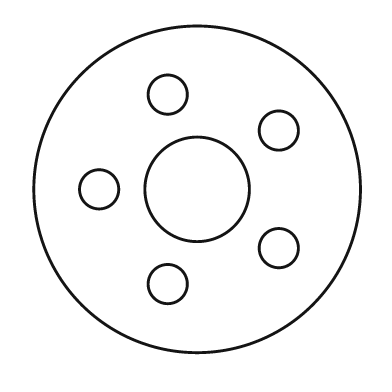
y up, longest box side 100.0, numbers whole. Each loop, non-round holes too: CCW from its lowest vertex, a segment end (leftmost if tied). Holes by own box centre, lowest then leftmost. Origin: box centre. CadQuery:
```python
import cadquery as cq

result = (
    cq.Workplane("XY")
    .moveTo(0.0, 0.0)
    .circle(50.0)
    .moveTo(-9.0, -29.0)
    .circle(6.0)
    .moveTo(25.0, -18.0)
    .circle(6.0)
    .moveTo(-30.0, 0.0)
    .circle(6.0)
    .moveTo(0.0, 0.0)
    .circle(16.0)
    .moveTo(25.0, 18.0)
    .circle(6.0)
    .moveTo(-9.0, 29.0)
    .circle(6.0)
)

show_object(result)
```